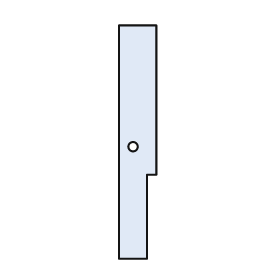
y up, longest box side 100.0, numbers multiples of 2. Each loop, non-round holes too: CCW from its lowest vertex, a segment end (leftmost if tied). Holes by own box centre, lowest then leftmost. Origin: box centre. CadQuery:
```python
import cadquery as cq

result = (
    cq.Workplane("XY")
    .moveTo(-8.0, -50.0)
    .lineTo(4.0, -50.0)
    .lineTo(4.0, -14.0)
    .lineTo(8.0, -14.0)
    .lineTo(8.0, 50.0)
    .lineTo(-8.0, 50.0)
    .close()
    .moveTo(-2.0, -2.0)
    .circle(2.0)
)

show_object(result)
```